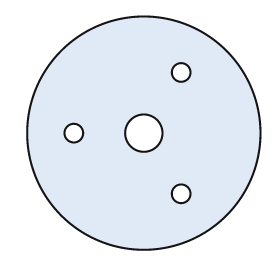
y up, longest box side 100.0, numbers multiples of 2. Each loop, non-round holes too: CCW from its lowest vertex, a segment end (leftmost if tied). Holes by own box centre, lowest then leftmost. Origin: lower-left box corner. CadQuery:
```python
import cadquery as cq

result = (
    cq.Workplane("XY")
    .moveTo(50.0, 50.0)
    .circle(50.0)
    .moveTo(66.0, 24.0)
    .circle(4.0)
    .moveTo(20.0, 50.0)
    .circle(4.0)
    .moveTo(50.0, 50.0)
    .circle(8.0)
    .moveTo(66.0, 76.0)
    .circle(4.0)
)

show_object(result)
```